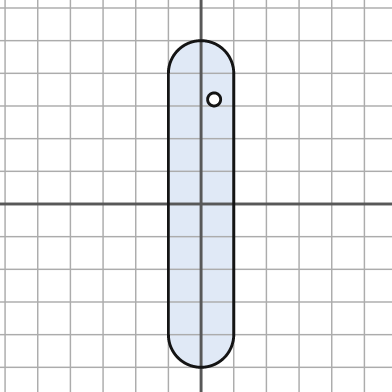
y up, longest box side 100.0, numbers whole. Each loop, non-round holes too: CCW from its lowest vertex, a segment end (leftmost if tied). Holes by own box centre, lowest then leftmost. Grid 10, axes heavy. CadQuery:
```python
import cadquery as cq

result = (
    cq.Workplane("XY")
    .moveTo(-10.0, -40.0)
    .threePointArc((0.0, -50.0), (10.0, -40.0))
    .lineTo(10.0, 40.0)
    .threePointArc((0.0, 50.0), (-10.0, 40.0))
    .close()
    .moveTo(4.0, 32.0)
    .circle(2.0)
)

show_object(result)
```